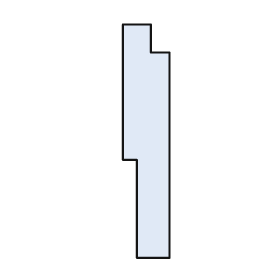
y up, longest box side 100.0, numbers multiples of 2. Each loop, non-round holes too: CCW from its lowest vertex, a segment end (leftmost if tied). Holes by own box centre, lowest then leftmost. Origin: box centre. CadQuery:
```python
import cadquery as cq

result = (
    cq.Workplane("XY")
    .moveTo(-4.0, -50.0)
    .lineTo(10.0, -50.0)
    .lineTo(10.0, 38.0)
    .lineTo(2.0, 38.0)
    .lineTo(2.0, 50.0)
    .lineTo(-10.0, 50.0)
    .lineTo(-10.0, -8.0)
    .lineTo(-4.0, -8.0)
    .close()
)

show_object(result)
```